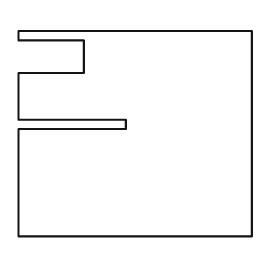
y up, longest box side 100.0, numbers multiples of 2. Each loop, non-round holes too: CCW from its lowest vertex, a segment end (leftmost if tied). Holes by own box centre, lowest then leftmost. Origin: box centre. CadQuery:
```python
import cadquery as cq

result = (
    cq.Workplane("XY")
    .moveTo(-50.0, -44.0)
    .lineTo(50.0, -44.0)
    .lineTo(50.0, 44.0)
    .lineTo(-50.0, 44.0)
    .lineTo(-50.0, 40.0)
    .lineTo(-22.0, 40.0)
    .lineTo(-22.0, 26.0)
    .lineTo(-50.0, 26.0)
    .lineTo(-50.0, 6.0)
    .lineTo(-4.0, 6.0)
    .lineTo(-4.0, 2.0)
    .lineTo(-50.0, 2.0)
    .close()
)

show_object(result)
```